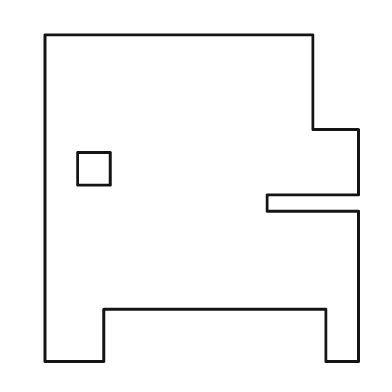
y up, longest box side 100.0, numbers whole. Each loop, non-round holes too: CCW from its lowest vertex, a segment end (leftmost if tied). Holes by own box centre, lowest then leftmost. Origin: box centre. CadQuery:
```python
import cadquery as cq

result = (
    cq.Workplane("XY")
    .moveTo(-48.0, -50.0)
    .lineTo(-30.0, -50.0)
    .lineTo(-30.0, -34.0)
    .lineTo(38.0, -34.0)
    .lineTo(38.0, -50.0)
    .lineTo(48.0, -50.0)
    .lineTo(48.0, -4.0)
    .lineTo(20.0, -4.0)
    .lineTo(20.0, 1.0)
    .lineTo(48.0, 1.0)
    .lineTo(48.0, 21.0)
    .lineTo(34.0, 21.0)
    .lineTo(34.0, 50.0)
    .lineTo(-48.0, 50.0)
    .close()
    .moveTo(-38.0, 4.0)
    .lineTo(-28.0, 4.0)
    .lineTo(-28.0, 14.0)
    .lineTo(-38.0, 14.0)
    .close()
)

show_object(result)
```